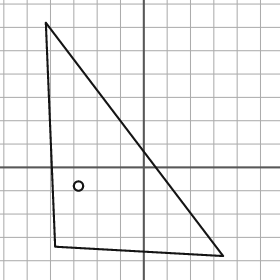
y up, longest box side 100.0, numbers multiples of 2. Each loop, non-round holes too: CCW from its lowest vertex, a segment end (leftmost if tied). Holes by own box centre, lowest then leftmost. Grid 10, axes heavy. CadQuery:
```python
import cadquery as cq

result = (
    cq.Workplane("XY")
    .moveTo(34.0, -38.0)
    .lineTo(-42.0, 62.0)
    .lineTo(-38.0, -34.0)
    .close()
    .moveTo(-28.0, -8.0)
    .circle(2.0)
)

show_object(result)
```